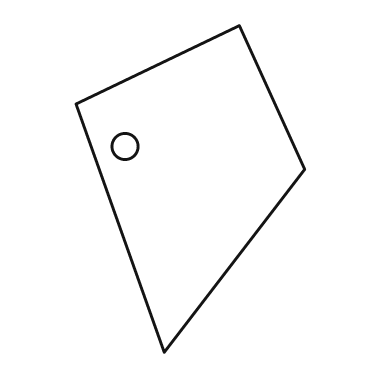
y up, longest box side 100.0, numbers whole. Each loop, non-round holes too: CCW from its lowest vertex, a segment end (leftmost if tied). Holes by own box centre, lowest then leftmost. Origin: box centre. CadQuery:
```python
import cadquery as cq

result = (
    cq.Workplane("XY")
    .moveTo(-8.0, -50.0)
    .lineTo(35.0, 6.0)
    .lineTo(15.0, 50.0)
    .lineTo(-35.0, 26.0)
    .close()
    .moveTo(-20.0, 13.0)
    .circle(4.0)
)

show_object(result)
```